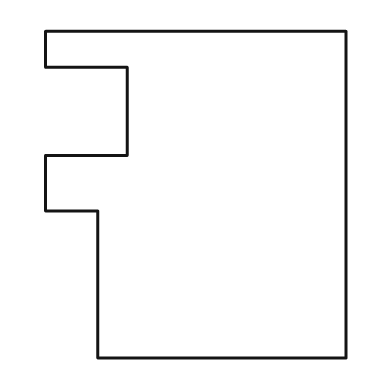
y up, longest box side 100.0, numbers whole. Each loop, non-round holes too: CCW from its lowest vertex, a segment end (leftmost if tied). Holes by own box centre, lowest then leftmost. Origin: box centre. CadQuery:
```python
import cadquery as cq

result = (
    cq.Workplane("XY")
    .moveTo(-30.0, -50.0)
    .lineTo(46.0, -50.0)
    .lineTo(46.0, 50.0)
    .lineTo(-46.0, 50.0)
    .lineTo(-46.0, 39.0)
    .lineTo(-21.0, 39.0)
    .lineTo(-21.0, 12.0)
    .lineTo(-46.0, 12.0)
    .lineTo(-46.0, -5.0)
    .lineTo(-30.0, -5.0)
    .close()
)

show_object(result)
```